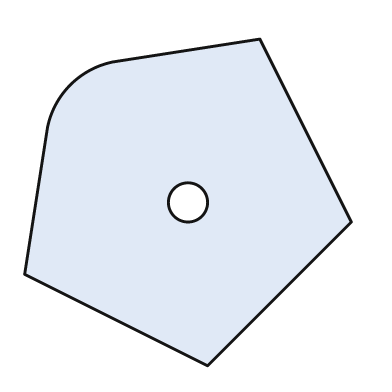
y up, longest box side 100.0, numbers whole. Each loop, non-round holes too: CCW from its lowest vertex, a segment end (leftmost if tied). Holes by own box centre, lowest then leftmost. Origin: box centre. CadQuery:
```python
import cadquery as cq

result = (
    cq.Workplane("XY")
    .moveTo(6.0, -50.0)
    .lineTo(50.0, -6.0)
    .lineTo(22.0, 50.0)
    .lineTo(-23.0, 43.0)
    .threePointArc((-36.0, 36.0), (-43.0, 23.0))
    .lineTo(-50.0, -22.0)
    .close()
    .moveTo(0.0, 0.0)
    .circle(6.0)
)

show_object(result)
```